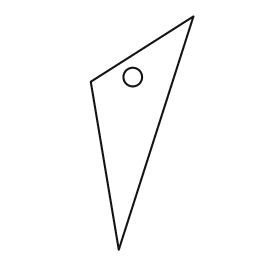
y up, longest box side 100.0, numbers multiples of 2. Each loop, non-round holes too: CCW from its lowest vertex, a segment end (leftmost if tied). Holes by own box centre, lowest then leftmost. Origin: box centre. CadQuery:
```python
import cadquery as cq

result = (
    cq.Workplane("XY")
    .moveTo(-10.0, -50.0)
    .lineTo(22.0, 50.0)
    .lineTo(-22.0, 22.0)
    .close()
    .moveTo(-4.0, 24.0)
    .circle(4.0)
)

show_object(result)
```